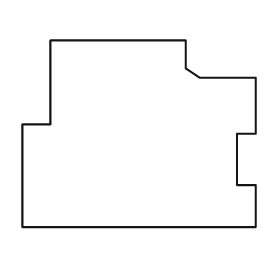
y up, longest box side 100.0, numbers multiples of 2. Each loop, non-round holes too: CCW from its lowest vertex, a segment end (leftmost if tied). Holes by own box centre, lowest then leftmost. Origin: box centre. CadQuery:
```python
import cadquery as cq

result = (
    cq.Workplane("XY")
    .moveTo(-50.0, -40.0)
    .lineTo(50.0, -40.0)
    .lineTo(50.0, -22.0)
    .lineTo(42.0, -22.0)
    .lineTo(42.0, 0.0)
    .lineTo(50.0, 0.0)
    .lineTo(50.0, 24.0)
    .lineTo(26.0, 24.0)
    .lineTo(20.0, 28.0)
    .lineTo(20.0, 40.0)
    .lineTo(-38.0, 40.0)
    .lineTo(-38.0, 4.0)
    .lineTo(-50.0, 4.0)
    .close()
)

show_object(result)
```